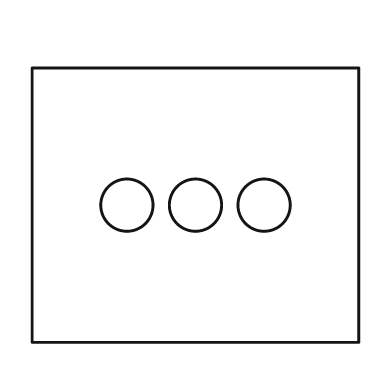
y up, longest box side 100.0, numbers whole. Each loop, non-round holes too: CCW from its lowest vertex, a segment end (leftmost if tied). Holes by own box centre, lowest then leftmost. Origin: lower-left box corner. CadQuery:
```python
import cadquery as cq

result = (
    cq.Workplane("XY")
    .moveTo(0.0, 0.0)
    .lineTo(100.0, 0.0)
    .lineTo(100.0, 84.0)
    .lineTo(0.0, 84.0)
    .close()
    .moveTo(29.0, 42.0)
    .circle(8.0)
    .moveTo(50.0, 42.0)
    .circle(8.0)
    .moveTo(71.0, 42.0)
    .circle(8.0)
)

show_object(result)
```